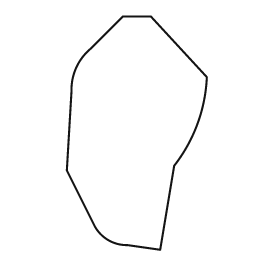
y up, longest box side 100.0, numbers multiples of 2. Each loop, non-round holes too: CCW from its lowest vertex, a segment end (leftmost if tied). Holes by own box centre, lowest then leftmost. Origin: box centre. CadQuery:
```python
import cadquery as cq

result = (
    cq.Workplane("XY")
    .moveTo(10.0, -50.0)
    .lineTo(16.0, -14.0)
    .threePointArc((26.0, 4.0), (30.0, 24.0))
    .lineTo(6.0, 50.0)
    .lineTo(-6.0, 50.0)
    .lineTo(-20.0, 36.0)
    .threePointArc((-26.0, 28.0), (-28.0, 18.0))
    .lineTo(-30.0, -16.0)
    .lineTo(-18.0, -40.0)
    .threePointArc((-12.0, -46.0), (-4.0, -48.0))
    .close()
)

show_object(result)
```